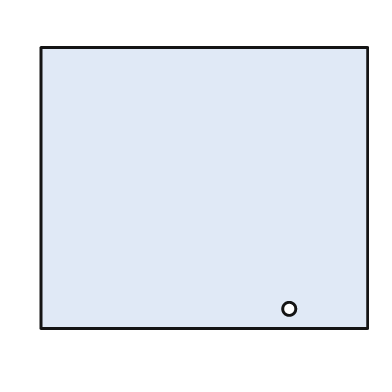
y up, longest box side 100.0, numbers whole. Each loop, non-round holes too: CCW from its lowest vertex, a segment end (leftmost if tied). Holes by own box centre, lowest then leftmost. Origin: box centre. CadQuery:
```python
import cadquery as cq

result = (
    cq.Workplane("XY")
    .moveTo(-50.0, -43.0)
    .lineTo(50.0, -43.0)
    .lineTo(50.0, 43.0)
    .lineTo(-50.0, 43.0)
    .close()
    .moveTo(26.0, -37.0)
    .circle(2.0)
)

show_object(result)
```